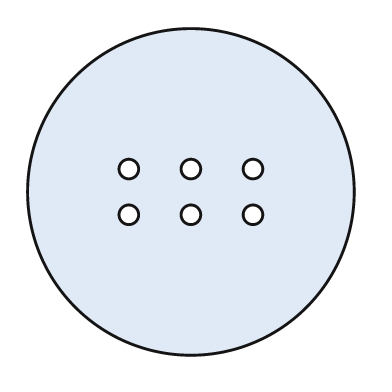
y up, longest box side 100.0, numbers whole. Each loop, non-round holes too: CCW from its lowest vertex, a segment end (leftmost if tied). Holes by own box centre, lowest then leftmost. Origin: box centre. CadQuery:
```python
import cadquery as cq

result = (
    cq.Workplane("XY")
    .moveTo(0.0, 0.0)
    .circle(50.0)
    .moveTo(-19.0, -7.0)
    .circle(3.0)
    .moveTo(0.0, -7.0)
    .circle(3.0)
    .moveTo(19.0, -7.0)
    .circle(3.0)
    .moveTo(-19.0, 7.0)
    .circle(3.0)
    .moveTo(0.0, 7.0)
    .circle(3.0)
    .moveTo(19.0, 7.0)
    .circle(3.0)
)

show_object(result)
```